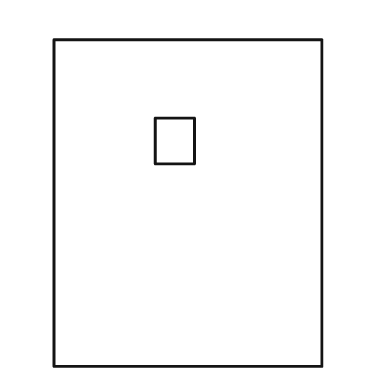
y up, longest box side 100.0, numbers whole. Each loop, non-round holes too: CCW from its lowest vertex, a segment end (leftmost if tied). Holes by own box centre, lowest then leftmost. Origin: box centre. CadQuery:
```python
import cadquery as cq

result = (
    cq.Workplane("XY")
    .moveTo(-41.0, -50.0)
    .lineTo(41.0, -50.0)
    .lineTo(41.0, 50.0)
    .lineTo(-41.0, 50.0)
    .close()
    .moveTo(-10.0, 12.0)
    .lineTo(2.0, 12.0)
    .lineTo(2.0, 26.0)
    .lineTo(-10.0, 26.0)
    .close()
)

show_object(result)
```